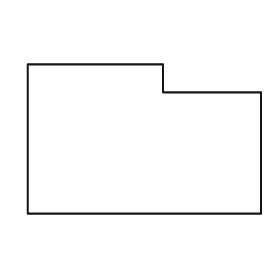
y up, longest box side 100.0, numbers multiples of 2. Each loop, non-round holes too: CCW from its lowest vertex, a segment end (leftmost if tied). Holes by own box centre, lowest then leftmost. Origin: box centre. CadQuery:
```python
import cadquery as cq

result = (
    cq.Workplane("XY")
    .moveTo(-50.0, -32.0)
    .lineTo(50.0, -32.0)
    .lineTo(50.0, 20.0)
    .lineTo(8.0, 20.0)
    .lineTo(8.0, 32.0)
    .lineTo(-50.0, 32.0)
    .close()
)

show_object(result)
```